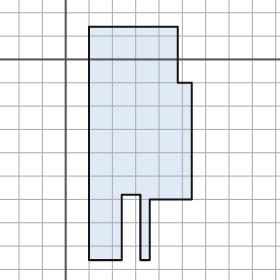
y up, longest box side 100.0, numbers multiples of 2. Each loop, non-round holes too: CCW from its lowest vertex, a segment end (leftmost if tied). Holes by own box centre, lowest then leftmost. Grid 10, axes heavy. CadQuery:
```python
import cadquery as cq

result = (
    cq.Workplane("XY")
    .moveTo(10.0, -86.0)
    .lineTo(24.0, -86.0)
    .lineTo(24.0, -58.0)
    .lineTo(32.0, -58.0)
    .lineTo(32.0, -86.0)
    .lineTo(36.0, -86.0)
    .lineTo(36.0, -60.0)
    .lineTo(54.0, -60.0)
    .lineTo(54.0, -10.0)
    .lineTo(48.0, -10.0)
    .lineTo(48.0, 14.0)
    .lineTo(10.0, 14.0)
    .close()
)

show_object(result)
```